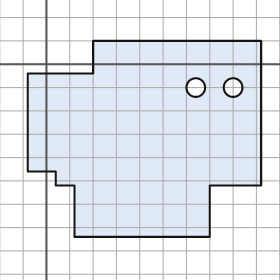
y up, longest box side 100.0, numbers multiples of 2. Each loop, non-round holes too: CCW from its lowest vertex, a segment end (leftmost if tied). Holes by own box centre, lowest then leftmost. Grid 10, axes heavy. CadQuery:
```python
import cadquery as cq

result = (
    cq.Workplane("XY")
    .moveTo(12.0, -74.0)
    .lineTo(70.0, -74.0)
    .lineTo(70.0, -52.0)
    .lineTo(92.0, -52.0)
    .lineTo(92.0, 10.0)
    .lineTo(20.0, 10.0)
    .lineTo(20.0, -4.0)
    .lineTo(-8.0, -4.0)
    .lineTo(-8.0, -46.0)
    .lineTo(4.0, -46.0)
    .lineTo(4.0, -52.0)
    .lineTo(12.0, -52.0)
    .close()
    .moveTo(64.0, -10.0)
    .circle(4.0)
    .moveTo(80.0, -10.0)
    .circle(4.0)
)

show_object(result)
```